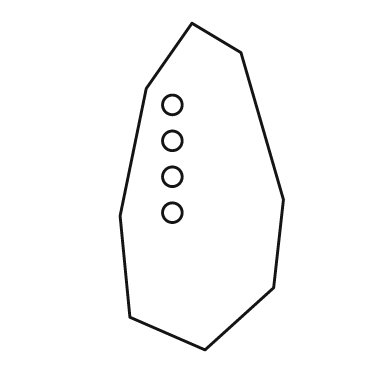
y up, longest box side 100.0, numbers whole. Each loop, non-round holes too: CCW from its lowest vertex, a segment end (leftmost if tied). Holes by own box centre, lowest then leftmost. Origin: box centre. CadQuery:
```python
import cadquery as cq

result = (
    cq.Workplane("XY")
    .moveTo(1.0, -50.0)
    .lineTo(22.0, -31.0)
    .lineTo(25.0, -4.0)
    .lineTo(12.0, 41.0)
    .lineTo(-3.0, 50.0)
    .lineTo(-17.0, 30.0)
    .lineTo(-25.0, -9.0)
    .lineTo(-22.0, -40.0)
    .close()
    .moveTo(-9.0, -8.0)
    .circle(3.0)
    .moveTo(-9.0, 3.0)
    .circle(3.0)
    .moveTo(-9.0, 14.0)
    .circle(3.0)
    .moveTo(-9.0, 25.0)
    .circle(3.0)
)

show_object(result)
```